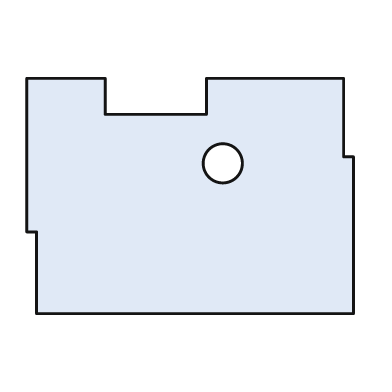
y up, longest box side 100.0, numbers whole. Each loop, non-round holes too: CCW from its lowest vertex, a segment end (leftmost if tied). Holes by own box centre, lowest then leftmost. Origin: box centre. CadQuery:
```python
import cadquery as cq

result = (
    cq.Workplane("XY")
    .moveTo(-47.0, -36.0)
    .lineTo(50.0, -36.0)
    .lineTo(50.0, 12.0)
    .lineTo(47.0, 12.0)
    .lineTo(47.0, 36.0)
    .lineTo(5.0, 36.0)
    .lineTo(5.0, 25.0)
    .lineTo(-26.0, 25.0)
    .lineTo(-26.0, 36.0)
    .lineTo(-50.0, 36.0)
    .lineTo(-50.0, -11.0)
    .lineTo(-47.0, -11.0)
    .close()
    .moveTo(10.0, 10.0)
    .circle(6.0)
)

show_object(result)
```